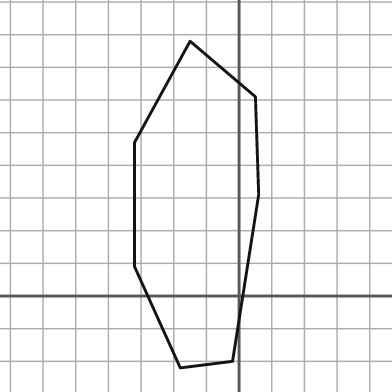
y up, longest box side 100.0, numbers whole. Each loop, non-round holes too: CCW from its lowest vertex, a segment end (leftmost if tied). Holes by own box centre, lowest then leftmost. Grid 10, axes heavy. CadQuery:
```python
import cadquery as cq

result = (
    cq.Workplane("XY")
    .moveTo(-18.0, -22.0)
    .lineTo(-2.0, -20.0)
    .lineTo(6.0, 31.0)
    .lineTo(5.0, 61.0)
    .lineTo(-15.0, 78.0)
    .lineTo(-32.0, 47.0)
    .lineTo(-32.0, 9.0)
    .close()
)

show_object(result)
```